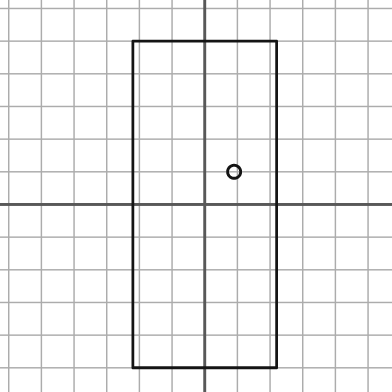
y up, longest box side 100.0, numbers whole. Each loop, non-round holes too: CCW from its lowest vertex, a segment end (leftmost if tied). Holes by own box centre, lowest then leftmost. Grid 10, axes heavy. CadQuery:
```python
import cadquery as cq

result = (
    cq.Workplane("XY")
    .moveTo(-22.0, -50.0)
    .lineTo(22.0, -50.0)
    .lineTo(22.0, 50.0)
    .lineTo(-22.0, 50.0)
    .close()
    .moveTo(9.0, 10.0)
    .circle(2.0)
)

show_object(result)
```